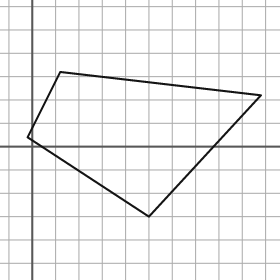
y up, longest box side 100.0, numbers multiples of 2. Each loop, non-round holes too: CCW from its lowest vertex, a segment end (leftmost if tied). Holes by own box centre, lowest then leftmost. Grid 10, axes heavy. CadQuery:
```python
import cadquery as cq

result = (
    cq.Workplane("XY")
    .moveTo(50.0, -30.0)
    .lineTo(98.0, 22.0)
    .lineTo(12.0, 32.0)
    .lineTo(-2.0, 4.0)
    .close()
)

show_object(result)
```